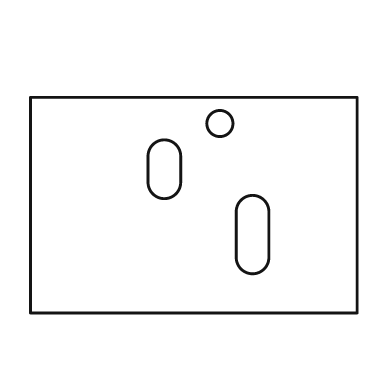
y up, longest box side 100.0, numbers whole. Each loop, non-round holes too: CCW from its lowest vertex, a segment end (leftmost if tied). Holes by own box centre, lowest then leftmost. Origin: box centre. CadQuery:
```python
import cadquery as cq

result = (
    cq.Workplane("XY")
    .moveTo(-50.0, -33.0)
    .lineTo(50.0, -33.0)
    .lineTo(50.0, 33.0)
    .lineTo(-50.0, 33.0)
    .close()
    .moveTo(13.0, -16.0)
    .threePointArc((18.0, -21.0), (23.0, -16.0))
    .lineTo(23.0, -2.0)
    .threePointArc((18.0, 3.0), (13.0, -2.0))
    .close()
    .moveTo(-14.0, 7.0)
    .threePointArc((-9.0, 2.0), (-4.0, 7.0))
    .lineTo(-4.0, 15.0)
    .threePointArc((-9.0, 20.0), (-14.0, 15.0))
    .close()
    .moveTo(8.0, 25.0)
    .circle(4.0)
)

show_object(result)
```